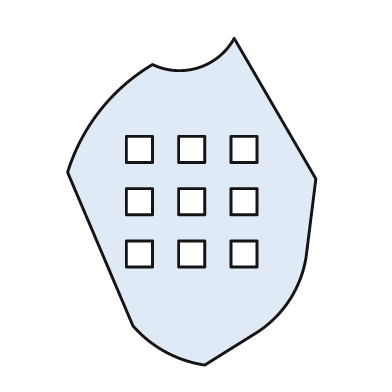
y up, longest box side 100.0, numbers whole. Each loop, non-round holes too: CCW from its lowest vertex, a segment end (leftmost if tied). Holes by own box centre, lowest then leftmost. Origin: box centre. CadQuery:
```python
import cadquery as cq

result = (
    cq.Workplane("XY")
    .moveTo(4.0, -50.0)
    .lineTo(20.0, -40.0)
    .threePointArc((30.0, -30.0), (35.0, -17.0))
    .lineTo(38.0, 7.0)
    .lineTo(13.0, 50.0)
    .threePointArc((2.0, 41.0), (-12.0, 42.0))
    .threePointArc((-28.0, 28.0), (-38.0, 9.0))
    .lineTo(-18.0, -38.0)
    .threePointArc((-8.0, -46.0), (4.0, -50.0))
    .close()
    .moveTo(-20.0, -20.0)
    .lineTo(-12.0, -20.0)
    .lineTo(-12.0, -12.0)
    .lineTo(-20.0, -12.0)
    .close()
    .moveTo(-4.0, -20.0)
    .lineTo(4.0, -20.0)
    .lineTo(4.0, -12.0)
    .lineTo(-4.0, -12.0)
    .close()
    .moveTo(12.0, -20.0)
    .lineTo(20.0, -20.0)
    .lineTo(20.0, -12.0)
    .lineTo(12.0, -12.0)
    .close()
    .moveTo(-20.0, -4.0)
    .lineTo(-12.0, -4.0)
    .lineTo(-12.0, 4.0)
    .lineTo(-20.0, 4.0)
    .close()
    .moveTo(-4.0, -4.0)
    .lineTo(4.0, -4.0)
    .lineTo(4.0, 4.0)
    .lineTo(-4.0, 4.0)
    .close()
    .moveTo(12.0, -4.0)
    .lineTo(20.0, -4.0)
    .lineTo(20.0, 4.0)
    .lineTo(12.0, 4.0)
    .close()
    .moveTo(-20.0, 12.0)
    .lineTo(-12.0, 12.0)
    .lineTo(-12.0, 20.0)
    .lineTo(-20.0, 20.0)
    .close()
    .moveTo(-4.0, 12.0)
    .lineTo(4.0, 12.0)
    .lineTo(4.0, 20.0)
    .lineTo(-4.0, 20.0)
    .close()
    .moveTo(12.0, 12.0)
    .lineTo(20.0, 12.0)
    .lineTo(20.0, 20.0)
    .lineTo(12.0, 20.0)
    .close()
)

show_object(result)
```